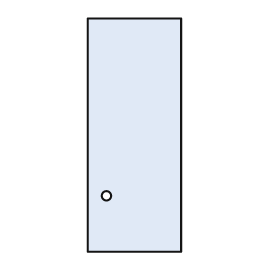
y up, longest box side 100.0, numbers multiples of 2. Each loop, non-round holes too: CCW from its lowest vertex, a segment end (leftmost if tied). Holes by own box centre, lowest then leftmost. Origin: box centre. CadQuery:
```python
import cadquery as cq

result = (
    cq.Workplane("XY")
    .moveTo(-20.0, -50.0)
    .lineTo(20.0, -50.0)
    .lineTo(20.0, 50.0)
    .lineTo(-20.0, 50.0)
    .close()
    .moveTo(-12.0, -26.0)
    .circle(2.0)
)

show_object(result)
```